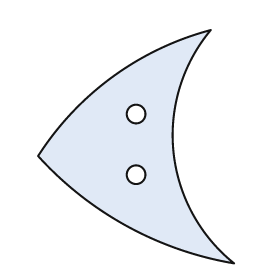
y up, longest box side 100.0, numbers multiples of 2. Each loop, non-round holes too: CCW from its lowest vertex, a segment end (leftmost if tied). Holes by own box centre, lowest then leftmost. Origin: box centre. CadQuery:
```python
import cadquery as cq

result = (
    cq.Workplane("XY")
    .moveTo(42.0, -50.0)
    .threePointArc((16.0, -2.0), (32.0, 50.0))
    .threePointArc((-10.0, 30.0), (-42.0, -4.0))
    .threePointArc((-4.0, -34.0), (42.0, -50.0))
    .close()
    .moveTo(0.0, -12.0)
    .circle(4.0)
    .moveTo(0.0, 14.0)
    .circle(4.0)
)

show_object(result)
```